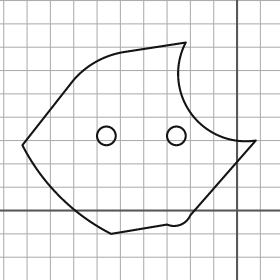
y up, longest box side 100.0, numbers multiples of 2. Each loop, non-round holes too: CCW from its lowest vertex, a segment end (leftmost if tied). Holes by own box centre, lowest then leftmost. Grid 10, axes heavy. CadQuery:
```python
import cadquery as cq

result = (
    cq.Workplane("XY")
    .moveTo(-54.0, -10.0)
    .lineTo(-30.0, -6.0)
    .threePointArc((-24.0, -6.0), (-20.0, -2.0))
    .lineTo(8.0, 30.0)
    .threePointArc((-20.0, 42.0), (-22.0, 72.0))
    .lineTo(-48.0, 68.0)
    .threePointArc((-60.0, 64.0), (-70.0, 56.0))
    .lineTo(-92.0, 28.0)
    .threePointArc((-76.0, 6.0), (-54.0, -10.0))
    .close()
    .moveTo(-56.0, 32.0)
    .circle(4.0)
    .moveTo(-26.0, 32.0)
    .circle(4.0)
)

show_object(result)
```